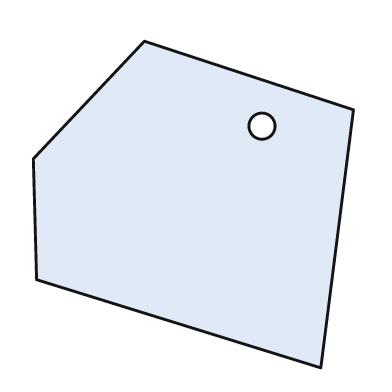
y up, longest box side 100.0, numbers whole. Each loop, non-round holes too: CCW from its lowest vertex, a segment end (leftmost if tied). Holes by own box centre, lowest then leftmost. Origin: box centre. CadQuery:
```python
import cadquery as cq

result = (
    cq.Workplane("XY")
    .moveTo(39.0, -50.0)
    .lineTo(49.0, 29.0)
    .lineTo(-15.0, 50.0)
    .lineTo(-49.0, 14.0)
    .lineTo(-48.0, -23.0)
    .close()
    .moveTo(21.0, 24.0)
    .circle(4.0)
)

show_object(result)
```